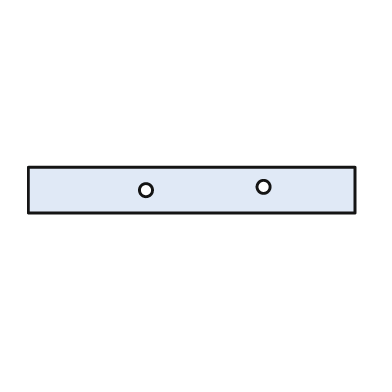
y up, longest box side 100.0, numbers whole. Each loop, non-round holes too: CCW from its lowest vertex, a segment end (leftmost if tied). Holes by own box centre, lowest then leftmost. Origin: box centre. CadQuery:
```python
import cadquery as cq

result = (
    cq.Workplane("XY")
    .moveTo(-50.0, -7.0)
    .lineTo(50.0, -7.0)
    .lineTo(50.0, 7.0)
    .lineTo(-50.0, 7.0)
    .close()
    .moveTo(-14.0, 0.0)
    .circle(2.0)
    .moveTo(22.0, 1.0)
    .circle(2.0)
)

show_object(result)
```